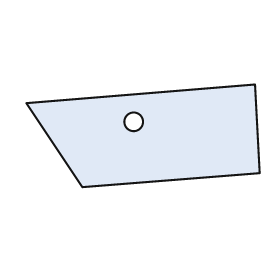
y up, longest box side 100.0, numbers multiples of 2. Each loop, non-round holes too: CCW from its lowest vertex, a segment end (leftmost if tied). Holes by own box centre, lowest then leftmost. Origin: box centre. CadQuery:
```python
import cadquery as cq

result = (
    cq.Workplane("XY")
    .moveTo(-26.0, -22.0)
    .lineTo(50.0, -16.0)
    .lineTo(48.0, 22.0)
    .lineTo(-50.0, 14.0)
    .close()
    .moveTo(-4.0, 6.0)
    .circle(4.0)
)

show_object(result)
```